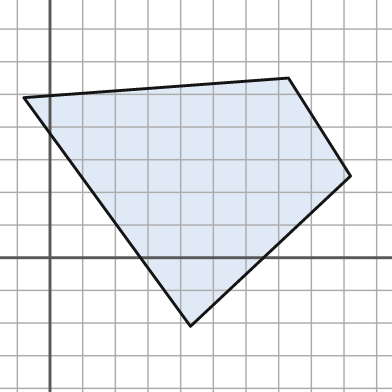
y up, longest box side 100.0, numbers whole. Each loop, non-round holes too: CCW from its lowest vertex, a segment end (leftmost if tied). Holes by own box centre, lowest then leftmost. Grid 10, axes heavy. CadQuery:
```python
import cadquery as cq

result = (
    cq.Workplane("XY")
    .moveTo(43.0, -21.0)
    .lineTo(92.0, 25.0)
    .lineTo(73.0, 55.0)
    .lineTo(-8.0, 49.0)
    .close()
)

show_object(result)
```